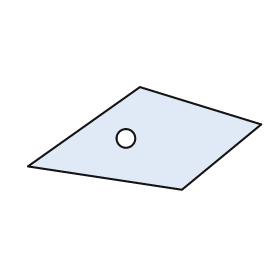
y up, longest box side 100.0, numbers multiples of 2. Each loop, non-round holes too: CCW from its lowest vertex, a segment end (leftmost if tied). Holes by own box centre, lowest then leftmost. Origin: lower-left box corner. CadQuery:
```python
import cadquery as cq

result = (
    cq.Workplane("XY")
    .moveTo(66.0, 0.0)
    .lineTo(100.0, 28.0)
    .lineTo(48.0, 44.0)
    .lineTo(0.0, 10.0)
    .close()
    .moveTo(42.0, 22.0)
    .circle(4.0)
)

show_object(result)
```